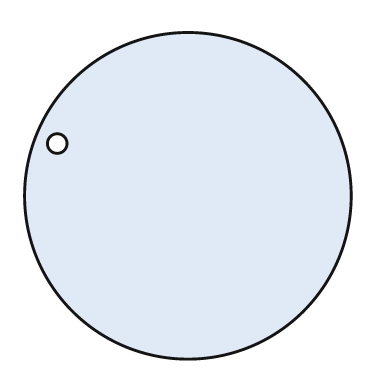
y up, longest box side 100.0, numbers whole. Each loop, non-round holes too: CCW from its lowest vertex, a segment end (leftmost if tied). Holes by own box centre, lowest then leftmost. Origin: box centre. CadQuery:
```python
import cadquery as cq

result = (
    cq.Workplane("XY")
    .moveTo(0.0, 0.0)
    .circle(50.0)
    .moveTo(-40.0, 16.0)
    .circle(3.0)
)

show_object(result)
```